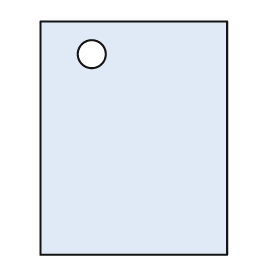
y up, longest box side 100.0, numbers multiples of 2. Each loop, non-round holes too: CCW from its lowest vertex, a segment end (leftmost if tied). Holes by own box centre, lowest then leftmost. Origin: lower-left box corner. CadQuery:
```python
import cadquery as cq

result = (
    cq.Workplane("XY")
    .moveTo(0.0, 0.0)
    .lineTo(80.0, 0.0)
    .lineTo(80.0, 100.0)
    .lineTo(0.0, 100.0)
    .close()
    .moveTo(22.0, 86.0)
    .circle(6.0)
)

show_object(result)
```